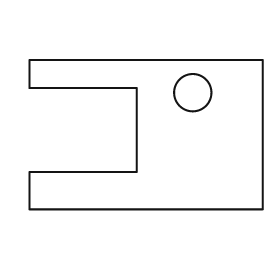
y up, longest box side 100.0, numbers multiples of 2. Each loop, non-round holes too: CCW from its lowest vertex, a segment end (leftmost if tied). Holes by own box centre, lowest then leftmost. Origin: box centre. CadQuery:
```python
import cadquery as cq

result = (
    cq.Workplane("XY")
    .moveTo(-50.0, -32.0)
    .lineTo(50.0, -32.0)
    .lineTo(50.0, 32.0)
    .lineTo(-50.0, 32.0)
    .lineTo(-50.0, 20.0)
    .lineTo(-4.0, 20.0)
    .lineTo(-4.0, -16.0)
    .lineTo(-50.0, -16.0)
    .close()
    .moveTo(20.0, 18.0)
    .circle(8.0)
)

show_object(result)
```